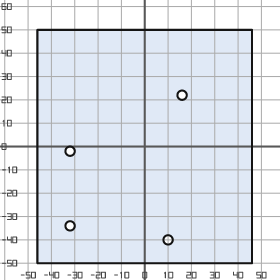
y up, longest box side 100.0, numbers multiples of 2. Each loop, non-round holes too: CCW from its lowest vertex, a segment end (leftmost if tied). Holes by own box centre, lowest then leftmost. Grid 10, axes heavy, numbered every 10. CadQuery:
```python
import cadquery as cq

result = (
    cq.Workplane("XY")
    .moveTo(-46.0, -50.0)
    .lineTo(46.0, -50.0)
    .lineTo(46.0, 50.0)
    .lineTo(-46.0, 50.0)
    .close()
    .moveTo(10.0, -40.0)
    .circle(2.0)
    .moveTo(-32.0, -34.0)
    .circle(2.0)
    .moveTo(-32.0, -2.0)
    .circle(2.0)
    .moveTo(16.0, 22.0)
    .circle(2.0)
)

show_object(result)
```